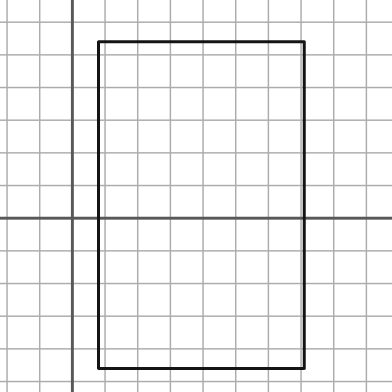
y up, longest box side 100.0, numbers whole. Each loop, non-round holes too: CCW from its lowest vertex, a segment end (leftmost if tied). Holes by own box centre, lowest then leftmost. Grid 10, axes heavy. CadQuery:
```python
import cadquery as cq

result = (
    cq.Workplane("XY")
    .moveTo(8.0, -46.0)
    .lineTo(71.0, -46.0)
    .lineTo(71.0, 54.0)
    .lineTo(8.0, 54.0)
    .close()
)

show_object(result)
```